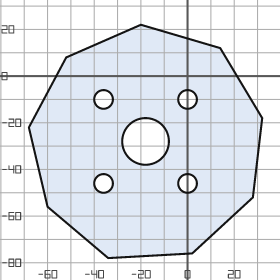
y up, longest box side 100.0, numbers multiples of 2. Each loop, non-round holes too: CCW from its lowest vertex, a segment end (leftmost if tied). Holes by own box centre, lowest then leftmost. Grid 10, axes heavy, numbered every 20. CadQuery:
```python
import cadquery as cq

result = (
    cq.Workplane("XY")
    .moveTo(-34.0, -78.0)
    .lineTo(2.0, -76.0)
    .lineTo(28.0, -52.0)
    .lineTo(32.0, -18.0)
    .lineTo(14.0, 12.0)
    .lineTo(-20.0, 22.0)
    .lineTo(-52.0, 8.0)
    .lineTo(-68.0, -22.0)
    .lineTo(-60.0, -56.0)
    .close()
    .moveTo(-36.0, -46.0)
    .circle(4.0)
    .moveTo(0.0, -46.0)
    .circle(4.0)
    .moveTo(-18.0, -28.0)
    .circle(10.0)
    .moveTo(-36.0, -10.0)
    .circle(4.0)
    .moveTo(0.0, -10.0)
    .circle(4.0)
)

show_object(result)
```